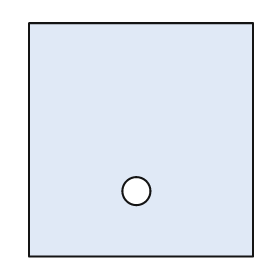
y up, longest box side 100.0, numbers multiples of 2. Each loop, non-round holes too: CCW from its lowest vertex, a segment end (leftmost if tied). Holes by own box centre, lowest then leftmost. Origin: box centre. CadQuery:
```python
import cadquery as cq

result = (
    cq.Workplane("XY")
    .moveTo(-48.0, -50.0)
    .lineTo(48.0, -50.0)
    .lineTo(48.0, 50.0)
    .lineTo(-48.0, 50.0)
    .close()
    .moveTo(-2.0, -22.0)
    .circle(6.0)
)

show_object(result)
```